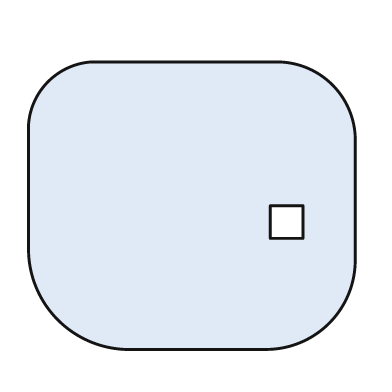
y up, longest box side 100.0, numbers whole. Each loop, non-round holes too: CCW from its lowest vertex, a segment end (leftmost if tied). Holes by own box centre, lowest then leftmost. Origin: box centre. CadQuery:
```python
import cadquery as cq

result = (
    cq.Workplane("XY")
    .moveTo(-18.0, -44.0)
    .lineTo(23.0, -44.0)
    .threePointArc((42.0, -36.0), (50.0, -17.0))
    .lineTo(50.0, 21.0)
    .threePointArc((43.0, 37.0), (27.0, 44.0))
    .lineTo(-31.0, 44.0)
    .threePointArc((-44.0, 38.0), (-50.0, 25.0))
    .lineTo(-50.0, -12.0)
    .threePointArc((-41.0, -35.0), (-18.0, -44.0))
    .close()
    .moveTo(24.0, -10.0)
    .lineTo(34.0, -10.0)
    .lineTo(34.0, 0.0)
    .lineTo(24.0, 0.0)
    .close()
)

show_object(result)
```